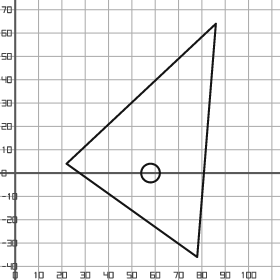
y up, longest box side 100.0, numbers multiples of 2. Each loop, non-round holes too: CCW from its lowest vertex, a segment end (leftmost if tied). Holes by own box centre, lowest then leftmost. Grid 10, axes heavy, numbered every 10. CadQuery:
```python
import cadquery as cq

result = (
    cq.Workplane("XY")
    .moveTo(78.0, -36.0)
    .lineTo(86.0, 64.0)
    .lineTo(22.0, 4.0)
    .close()
    .moveTo(58.0, 0.0)
    .circle(4.0)
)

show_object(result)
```